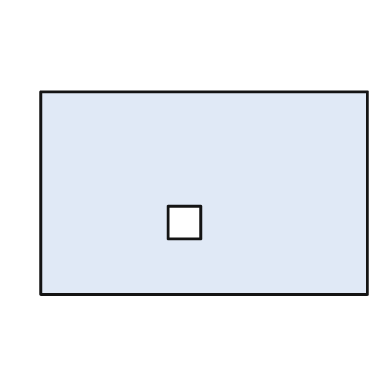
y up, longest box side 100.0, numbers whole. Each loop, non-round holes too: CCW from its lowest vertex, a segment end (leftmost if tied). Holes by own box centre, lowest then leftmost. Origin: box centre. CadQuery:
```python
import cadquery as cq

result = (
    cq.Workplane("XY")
    .moveTo(-50.0, -31.0)
    .lineTo(50.0, -31.0)
    .lineTo(50.0, 31.0)
    .lineTo(-50.0, 31.0)
    .close()
    .moveTo(-11.0, -14.0)
    .lineTo(-1.0, -14.0)
    .lineTo(-1.0, -4.0)
    .lineTo(-11.0, -4.0)
    .close()
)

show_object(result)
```